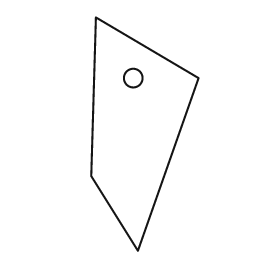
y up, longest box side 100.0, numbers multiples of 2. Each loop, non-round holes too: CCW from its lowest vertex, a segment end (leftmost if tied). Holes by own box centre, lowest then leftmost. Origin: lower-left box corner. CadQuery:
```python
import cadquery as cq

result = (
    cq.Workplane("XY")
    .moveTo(20.0, 0.0)
    .lineTo(46.0, 74.0)
    .lineTo(2.0, 100.0)
    .lineTo(0.0, 32.0)
    .close()
    .moveTo(18.0, 74.0)
    .circle(4.0)
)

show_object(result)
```